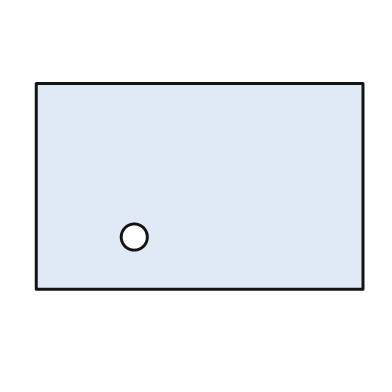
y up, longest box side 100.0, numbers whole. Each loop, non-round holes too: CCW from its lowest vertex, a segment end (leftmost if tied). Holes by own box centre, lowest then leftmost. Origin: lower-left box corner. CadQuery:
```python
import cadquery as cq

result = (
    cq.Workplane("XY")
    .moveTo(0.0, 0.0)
    .lineTo(100.0, 0.0)
    .lineTo(100.0, 63.0)
    .lineTo(0.0, 63.0)
    .close()
    .moveTo(30.0, 16.0)
    .circle(4.0)
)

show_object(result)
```